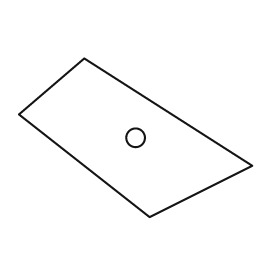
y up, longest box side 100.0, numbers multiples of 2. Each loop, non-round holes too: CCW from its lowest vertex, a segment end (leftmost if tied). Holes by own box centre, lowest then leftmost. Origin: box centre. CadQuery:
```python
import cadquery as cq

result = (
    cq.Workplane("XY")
    .moveTo(6.0, -34.0)
    .lineTo(50.0, -12.0)
    .lineTo(-22.0, 34.0)
    .lineTo(-50.0, 10.0)
    .close()
    .moveTo(0.0, 0.0)
    .circle(4.0)
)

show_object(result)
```